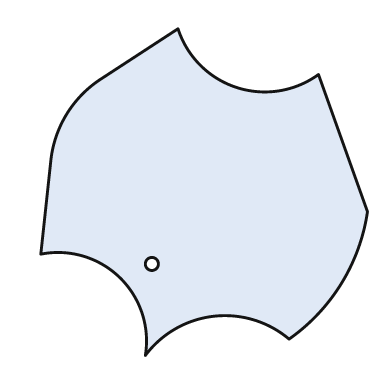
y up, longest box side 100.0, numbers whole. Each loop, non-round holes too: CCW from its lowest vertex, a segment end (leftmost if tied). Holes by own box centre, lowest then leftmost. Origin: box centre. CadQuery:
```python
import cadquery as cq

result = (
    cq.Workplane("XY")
    .moveTo(-18.0, -50.0)
    .threePointArc((3.0, -38.0), (26.0, -45.0))
    .threePointArc((42.0, -28.0), (50.0, -6.0))
    .lineTo(35.0, 36.0)
    .threePointArc((10.0, 32.0), (-8.0, 50.0))
    .lineTo(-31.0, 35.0)
    .threePointArc((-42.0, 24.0), (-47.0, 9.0))
    .lineTo(-50.0, -19.0)
    .threePointArc((-26.0, -26.0), (-18.0, -50.0))
    .close()
    .moveTo(-16.0, -22.0)
    .circle(2.0)
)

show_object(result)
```